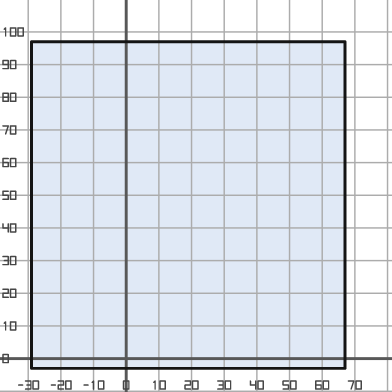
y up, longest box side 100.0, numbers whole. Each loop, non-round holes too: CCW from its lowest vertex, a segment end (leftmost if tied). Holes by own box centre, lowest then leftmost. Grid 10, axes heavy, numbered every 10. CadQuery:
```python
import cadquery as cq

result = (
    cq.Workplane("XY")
    .moveTo(-29.0, -3.0)
    .lineTo(67.0, -3.0)
    .lineTo(67.0, 97.0)
    .lineTo(-29.0, 97.0)
    .close()
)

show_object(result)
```